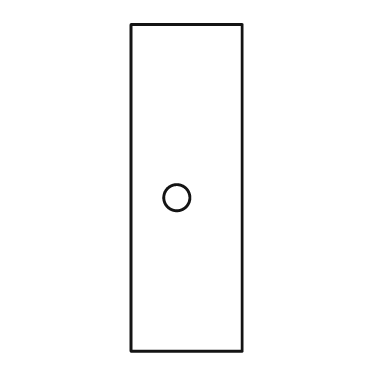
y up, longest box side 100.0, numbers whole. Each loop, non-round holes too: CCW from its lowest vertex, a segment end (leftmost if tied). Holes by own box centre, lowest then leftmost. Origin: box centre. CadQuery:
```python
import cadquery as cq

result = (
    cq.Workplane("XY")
    .moveTo(-17.0, -50.0)
    .lineTo(17.0, -50.0)
    .lineTo(17.0, 50.0)
    .lineTo(-17.0, 50.0)
    .close()
    .moveTo(-3.0, -3.0)
    .circle(4.0)
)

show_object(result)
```